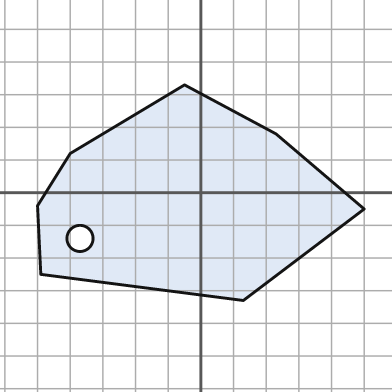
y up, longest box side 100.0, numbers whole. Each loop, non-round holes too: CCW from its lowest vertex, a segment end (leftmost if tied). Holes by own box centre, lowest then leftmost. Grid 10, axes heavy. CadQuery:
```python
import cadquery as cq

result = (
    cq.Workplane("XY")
    .moveTo(13.0, -33.0)
    .lineTo(50.0, -5.0)
    .lineTo(23.0, 18.0)
    .lineTo(-5.0, 33.0)
    .lineTo(-40.0, 12.0)
    .lineTo(-50.0, -4.0)
    .lineTo(-49.0, -25.0)
    .close()
    .moveTo(-37.0, -14.0)
    .circle(4.0)
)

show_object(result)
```